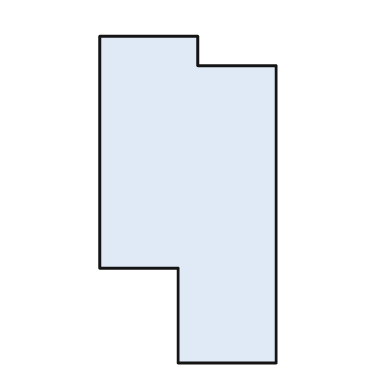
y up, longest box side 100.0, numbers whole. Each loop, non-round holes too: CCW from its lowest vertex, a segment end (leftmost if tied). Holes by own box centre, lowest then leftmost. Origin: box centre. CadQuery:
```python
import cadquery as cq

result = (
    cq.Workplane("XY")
    .moveTo(-3.0, -50.0)
    .lineTo(27.0, -50.0)
    .lineTo(27.0, 41.0)
    .lineTo(3.0, 41.0)
    .lineTo(3.0, 50.0)
    .lineTo(-27.0, 50.0)
    .lineTo(-27.0, -21.0)
    .lineTo(-3.0, -21.0)
    .close()
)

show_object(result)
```